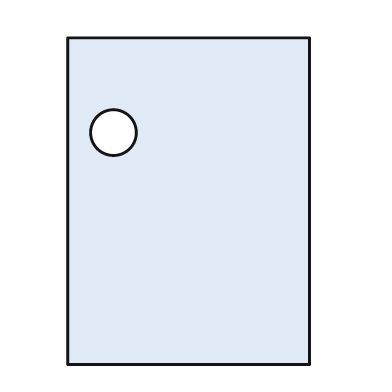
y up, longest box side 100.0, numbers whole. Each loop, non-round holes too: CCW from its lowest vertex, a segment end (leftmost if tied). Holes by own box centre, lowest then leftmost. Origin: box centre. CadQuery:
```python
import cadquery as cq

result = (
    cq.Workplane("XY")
    .moveTo(-37.0, -50.0)
    .lineTo(37.0, -50.0)
    .lineTo(37.0, 50.0)
    .lineTo(-37.0, 50.0)
    .close()
    .moveTo(-23.0, 21.0)
    .circle(7.0)
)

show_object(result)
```